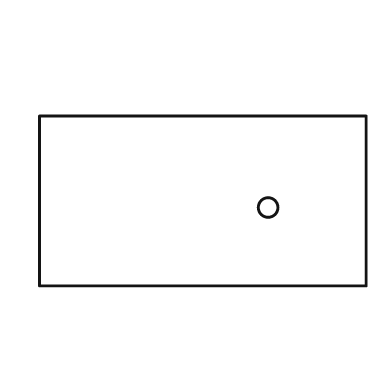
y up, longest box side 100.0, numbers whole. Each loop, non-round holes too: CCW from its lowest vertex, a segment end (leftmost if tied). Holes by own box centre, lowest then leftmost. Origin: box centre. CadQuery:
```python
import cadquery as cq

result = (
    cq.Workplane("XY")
    .moveTo(-50.0, -26.0)
    .lineTo(50.0, -26.0)
    .lineTo(50.0, 26.0)
    .lineTo(-50.0, 26.0)
    .close()
    .moveTo(20.0, -2.0)
    .circle(3.0)
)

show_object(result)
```